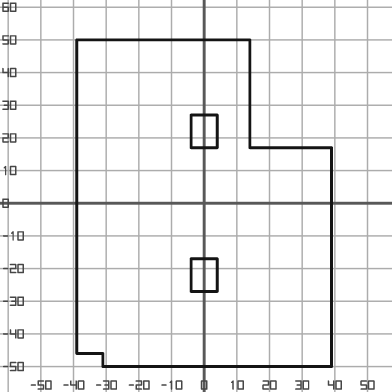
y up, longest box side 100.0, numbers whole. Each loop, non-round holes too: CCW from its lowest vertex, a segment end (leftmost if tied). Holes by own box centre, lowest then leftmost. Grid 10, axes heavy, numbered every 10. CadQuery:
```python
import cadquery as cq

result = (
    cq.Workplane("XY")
    .moveTo(-31.0, -50.0)
    .lineTo(39.0, -50.0)
    .lineTo(39.0, 17.0)
    .lineTo(14.0, 17.0)
    .lineTo(14.0, 50.0)
    .lineTo(-39.0, 50.0)
    .lineTo(-39.0, -46.0)
    .lineTo(-31.0, -46.0)
    .close()
    .moveTo(-4.0, -27.0)
    .lineTo(4.0, -27.0)
    .lineTo(4.0, -17.0)
    .lineTo(-4.0, -17.0)
    .close()
    .moveTo(-4.0, 17.0)
    .lineTo(4.0, 17.0)
    .lineTo(4.0, 27.0)
    .lineTo(-4.0, 27.0)
    .close()
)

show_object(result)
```